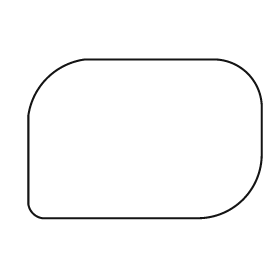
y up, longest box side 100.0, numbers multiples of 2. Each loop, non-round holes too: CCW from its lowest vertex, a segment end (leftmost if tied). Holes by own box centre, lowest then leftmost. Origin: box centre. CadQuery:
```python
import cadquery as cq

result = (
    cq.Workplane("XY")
    .moveTo(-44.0, -34.0)
    .lineTo(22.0, -34.0)
    .threePointArc((42.0, -26.0), (50.0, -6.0))
    .lineTo(50.0, 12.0)
    .threePointArc((44.0, 28.0), (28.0, 34.0))
    .lineTo(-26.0, 34.0)
    .threePointArc((-42.0, 26.0), (-50.0, 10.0))
    .lineTo(-50.0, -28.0)
    .threePointArc((-48.0, -32.0), (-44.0, -34.0))
    .close()
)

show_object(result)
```